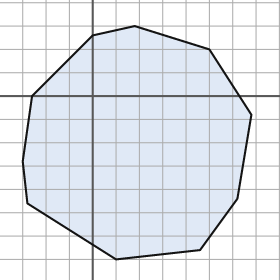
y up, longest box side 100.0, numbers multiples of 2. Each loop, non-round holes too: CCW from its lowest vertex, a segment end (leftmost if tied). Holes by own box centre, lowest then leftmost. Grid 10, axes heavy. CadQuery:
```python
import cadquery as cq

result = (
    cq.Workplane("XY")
    .moveTo(10.0, -70.0)
    .lineTo(46.0, -66.0)
    .lineTo(62.0, -44.0)
    .lineTo(68.0, -8.0)
    .lineTo(50.0, 20.0)
    .lineTo(18.0, 30.0)
    .lineTo(0.0, 26.0)
    .lineTo(-26.0, 0.0)
    .lineTo(-30.0, -28.0)
    .lineTo(-28.0, -46.0)
    .close()
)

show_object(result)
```